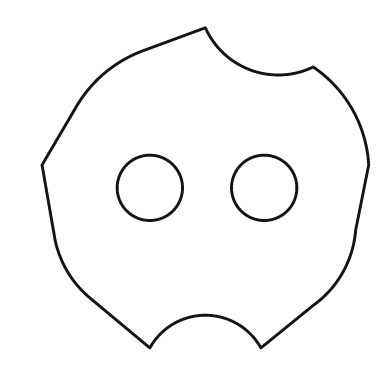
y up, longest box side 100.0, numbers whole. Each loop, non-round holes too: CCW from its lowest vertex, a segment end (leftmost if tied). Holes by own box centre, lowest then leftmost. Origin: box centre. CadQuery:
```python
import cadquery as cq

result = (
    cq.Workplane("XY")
    .moveTo(-17.0, -49.0)
    .threePointArc((0.0, -39.0), (17.0, -49.0))
    .lineTo(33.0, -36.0)
    .threePointArc((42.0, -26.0), (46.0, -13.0))
    .lineTo(50.0, 7.0)
    .threePointArc((45.0, 24.0), (33.0, 37.0))
    .threePointArc((14.0, 36.0), (0.0, 49.0))
    .lineTo(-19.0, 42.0)
    .threePointArc((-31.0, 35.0), (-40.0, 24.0))
    .lineTo(-50.0, 7.0)
    .lineTo(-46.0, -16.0)
    .threePointArc((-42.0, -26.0), (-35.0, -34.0))
    .close()
    .moveTo(-17.0, 0.0)
    .circle(10.0)
    .moveTo(18.0, 0.0)
    .circle(10.0)
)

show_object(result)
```